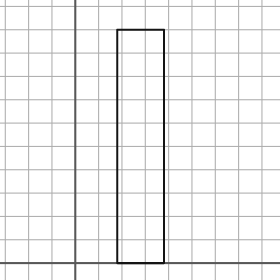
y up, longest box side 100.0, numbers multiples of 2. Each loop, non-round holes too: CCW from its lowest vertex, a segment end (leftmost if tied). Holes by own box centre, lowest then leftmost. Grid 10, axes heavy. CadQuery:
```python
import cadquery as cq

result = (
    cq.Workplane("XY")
    .moveTo(18.0, 0.0)
    .lineTo(38.0, 0.0)
    .lineTo(38.0, 100.0)
    .lineTo(18.0, 100.0)
    .close()
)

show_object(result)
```